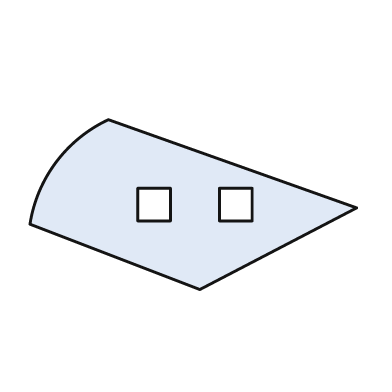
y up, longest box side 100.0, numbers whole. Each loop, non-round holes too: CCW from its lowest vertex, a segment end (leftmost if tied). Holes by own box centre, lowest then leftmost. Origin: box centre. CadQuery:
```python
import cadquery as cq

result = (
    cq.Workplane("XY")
    .moveTo(2.0, -26.0)
    .lineTo(50.0, -1.0)
    .lineTo(-26.0, 26.0)
    .threePointArc((-42.0, 13.0), (-50.0, -6.0))
    .close()
    .moveTo(-17.0, -5.0)
    .lineTo(-7.0, -5.0)
    .lineTo(-7.0, 5.0)
    .lineTo(-17.0, 5.0)
    .close()
    .moveTo(8.0, -5.0)
    .lineTo(18.0, -5.0)
    .lineTo(18.0, 5.0)
    .lineTo(8.0, 5.0)
    .close()
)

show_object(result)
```